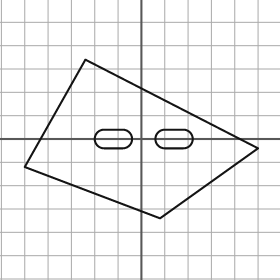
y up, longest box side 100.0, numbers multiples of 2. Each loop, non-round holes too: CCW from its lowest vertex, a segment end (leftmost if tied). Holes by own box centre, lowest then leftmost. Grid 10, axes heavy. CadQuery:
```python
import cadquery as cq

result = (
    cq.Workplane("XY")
    .moveTo(8.0, -34.0)
    .lineTo(50.0, -4.0)
    .lineTo(-24.0, 34.0)
    .lineTo(-50.0, -12.0)
    .close()
    .moveTo(-16.0, -4.0)
    .lineTo(-8.0, -4.0)
    .threePointArc((-4.0, 0.0), (-8.0, 4.0))
    .lineTo(-16.0, 4.0)
    .threePointArc((-20.0, 0.0), (-16.0, -4.0))
    .close()
    .moveTo(10.0, -4.0)
    .lineTo(18.0, -4.0)
    .threePointArc((22.0, 0.0), (18.0, 4.0))
    .lineTo(10.0, 4.0)
    .threePointArc((6.0, 0.0), (10.0, -4.0))
    .close()
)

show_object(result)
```